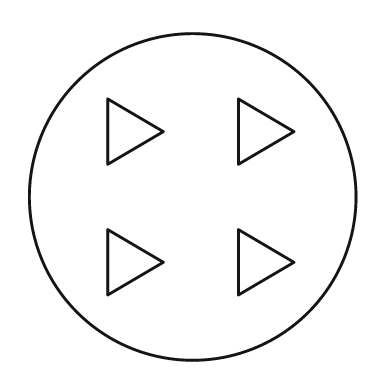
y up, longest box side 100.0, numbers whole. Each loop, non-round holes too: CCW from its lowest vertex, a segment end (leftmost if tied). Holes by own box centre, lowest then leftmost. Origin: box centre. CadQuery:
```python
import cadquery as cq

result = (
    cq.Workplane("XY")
    .moveTo(0.0, 0.0)
    .circle(50.0)
    .moveTo(-26.0, -30.0)
    .lineTo(-9.0, -20.0)
    .lineTo(-26.0, -10.0)
    .close()
    .moveTo(14.0, -30.0)
    .lineTo(31.0, -20.0)
    .lineTo(14.0, -10.0)
    .close()
    .moveTo(-26.0, 10.0)
    .lineTo(-9.0, 20.0)
    .lineTo(-26.0, 30.0)
    .close()
    .moveTo(14.0, 10.0)
    .lineTo(31.0, 20.0)
    .lineTo(14.0, 30.0)
    .close()
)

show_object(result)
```